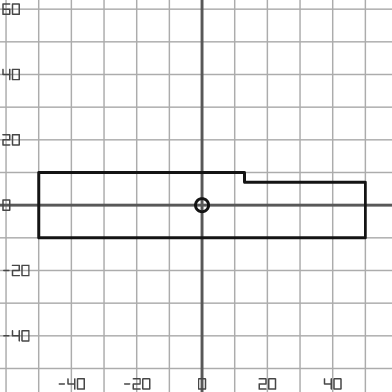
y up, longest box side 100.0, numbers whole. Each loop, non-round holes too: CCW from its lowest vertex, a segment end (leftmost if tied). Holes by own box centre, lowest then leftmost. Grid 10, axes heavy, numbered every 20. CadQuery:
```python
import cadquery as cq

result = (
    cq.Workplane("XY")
    .moveTo(-50.0, -10.0)
    .lineTo(50.0, -10.0)
    .lineTo(50.0, 7.0)
    .lineTo(13.0, 7.0)
    .lineTo(13.0, 10.0)
    .lineTo(-50.0, 10.0)
    .close()
    .moveTo(0.0, 0.0)
    .circle(2.0)
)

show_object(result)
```